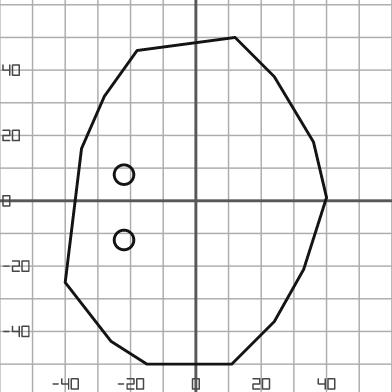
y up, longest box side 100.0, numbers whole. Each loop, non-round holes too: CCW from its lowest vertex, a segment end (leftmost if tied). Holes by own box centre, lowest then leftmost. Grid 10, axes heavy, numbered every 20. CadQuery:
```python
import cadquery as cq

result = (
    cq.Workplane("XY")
    .moveTo(-15.0, -50.0)
    .lineTo(11.0, -50.0)
    .lineTo(24.0, -37.0)
    .lineTo(33.0, -21.0)
    .lineTo(40.0, 1.0)
    .lineTo(36.0, 18.0)
    .lineTo(24.0, 38.0)
    .lineTo(12.0, 50.0)
    .lineTo(-18.0, 46.0)
    .lineTo(-28.0, 32.0)
    .lineTo(-35.0, 16.0)
    .lineTo(-40.0, -25.0)
    .lineTo(-26.0, -43.0)
    .close()
    .moveTo(-22.0, -12.0)
    .circle(3.0)
    .moveTo(-22.0, 8.0)
    .circle(3.0)
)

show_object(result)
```